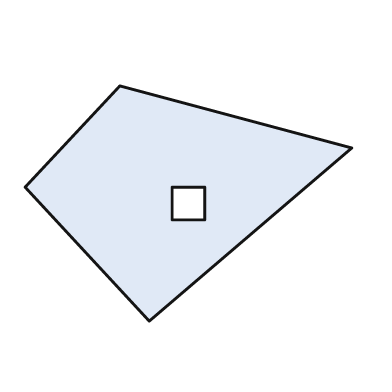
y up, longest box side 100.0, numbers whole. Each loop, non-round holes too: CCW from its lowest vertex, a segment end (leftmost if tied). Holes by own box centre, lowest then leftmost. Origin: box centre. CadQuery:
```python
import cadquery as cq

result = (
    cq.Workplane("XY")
    .moveTo(-12.0, -36.0)
    .lineTo(50.0, 17.0)
    .lineTo(-21.0, 36.0)
    .lineTo(-50.0, 5.0)
    .close()
    .moveTo(-5.0, -5.0)
    .lineTo(5.0, -5.0)
    .lineTo(5.0, 5.0)
    .lineTo(-5.0, 5.0)
    .close()
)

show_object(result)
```